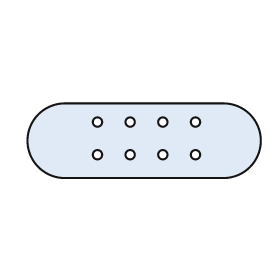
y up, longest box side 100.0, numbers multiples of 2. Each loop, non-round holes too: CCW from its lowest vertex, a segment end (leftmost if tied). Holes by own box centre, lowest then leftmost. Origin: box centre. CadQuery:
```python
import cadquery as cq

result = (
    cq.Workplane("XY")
    .moveTo(-34.0, -16.0)
    .lineTo(34.0, -16.0)
    .threePointArc((50.0, 0.0), (34.0, 16.0))
    .lineTo(-34.0, 16.0)
    .threePointArc((-50.0, 0.0), (-34.0, -16.0))
    .close()
    .moveTo(-20.0, -6.0)
    .circle(2.0)
    .moveTo(-6.0, -6.0)
    .circle(2.0)
    .moveTo(8.0, -6.0)
    .circle(2.0)
    .moveTo(22.0, -6.0)
    .circle(2.0)
    .moveTo(-20.0, 8.0)
    .circle(2.0)
    .moveTo(-6.0, 8.0)
    .circle(2.0)
    .moveTo(8.0, 8.0)
    .circle(2.0)
    .moveTo(22.0, 8.0)
    .circle(2.0)
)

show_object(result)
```